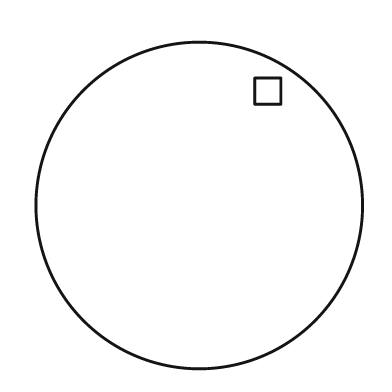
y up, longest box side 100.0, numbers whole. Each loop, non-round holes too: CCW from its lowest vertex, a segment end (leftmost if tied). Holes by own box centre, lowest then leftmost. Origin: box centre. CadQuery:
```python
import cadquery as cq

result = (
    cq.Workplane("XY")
    .moveTo(0.0, 0.0)
    .circle(50.0)
    .moveTo(17.0, 31.0)
    .lineTo(25.0, 31.0)
    .lineTo(25.0, 39.0)
    .lineTo(17.0, 39.0)
    .close()
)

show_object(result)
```